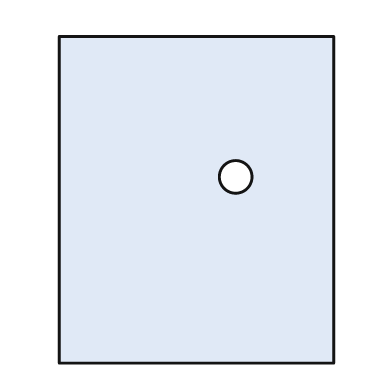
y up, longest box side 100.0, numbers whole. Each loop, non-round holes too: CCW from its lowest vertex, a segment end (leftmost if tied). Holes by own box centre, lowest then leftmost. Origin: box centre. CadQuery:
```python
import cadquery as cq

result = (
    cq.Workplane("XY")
    .moveTo(-42.0, -50.0)
    .lineTo(42.0, -50.0)
    .lineTo(42.0, 50.0)
    .lineTo(-42.0, 50.0)
    .close()
    .moveTo(12.0, 7.0)
    .circle(5.0)
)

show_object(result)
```